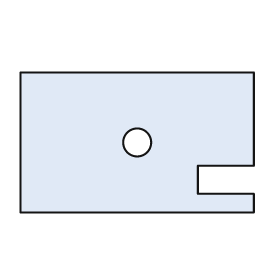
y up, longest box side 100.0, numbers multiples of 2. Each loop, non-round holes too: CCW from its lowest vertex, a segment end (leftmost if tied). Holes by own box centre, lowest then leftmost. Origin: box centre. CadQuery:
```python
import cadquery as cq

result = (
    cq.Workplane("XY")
    .moveTo(-50.0, -30.0)
    .lineTo(50.0, -30.0)
    .lineTo(50.0, -22.0)
    .lineTo(26.0, -22.0)
    .lineTo(26.0, -10.0)
    .lineTo(50.0, -10.0)
    .lineTo(50.0, 30.0)
    .lineTo(-50.0, 30.0)
    .close()
    .moveTo(0.0, 0.0)
    .circle(6.0)
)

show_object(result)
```